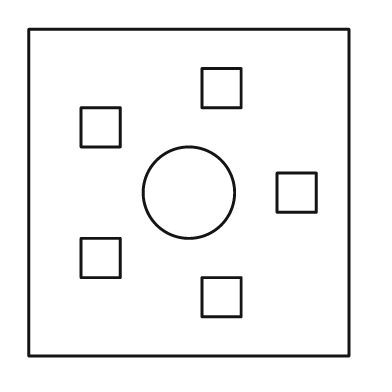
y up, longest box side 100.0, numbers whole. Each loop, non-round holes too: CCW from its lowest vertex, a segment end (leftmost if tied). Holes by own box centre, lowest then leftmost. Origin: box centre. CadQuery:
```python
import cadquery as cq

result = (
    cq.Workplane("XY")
    .moveTo(-49.0, -50.0)
    .lineTo(49.0, -50.0)
    .lineTo(49.0, 50.0)
    .lineTo(-49.0, 50.0)
    .close()
    .moveTo(4.0, -38.0)
    .lineTo(16.0, -38.0)
    .lineTo(16.0, -26.0)
    .lineTo(4.0, -26.0)
    .close()
    .moveTo(-33.0, -26.0)
    .lineTo(-21.0, -26.0)
    .lineTo(-21.0, -14.0)
    .lineTo(-33.0, -14.0)
    .close()
    .moveTo(0.0, 0.0)
    .circle(14.0)
    .moveTo(27.0, -6.0)
    .lineTo(39.0, -6.0)
    .lineTo(39.0, 6.0)
    .lineTo(27.0, 6.0)
    .close()
    .moveTo(-33.0, 14.0)
    .lineTo(-21.0, 14.0)
    .lineTo(-21.0, 26.0)
    .lineTo(-33.0, 26.0)
    .close()
    .moveTo(4.0, 26.0)
    .lineTo(16.0, 26.0)
    .lineTo(16.0, 38.0)
    .lineTo(4.0, 38.0)
    .close()
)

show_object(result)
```